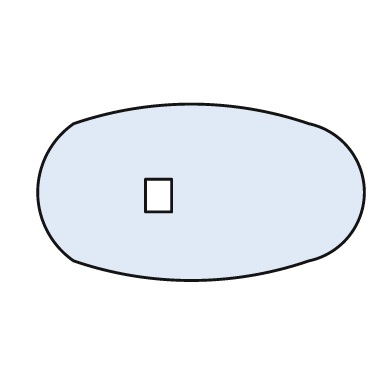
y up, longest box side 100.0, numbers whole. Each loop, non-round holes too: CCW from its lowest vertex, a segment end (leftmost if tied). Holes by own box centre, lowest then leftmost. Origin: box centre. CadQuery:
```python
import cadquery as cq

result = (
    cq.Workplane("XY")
    .moveTo(-39.0, -21.0)
    .threePointArc((-3.0, -27.0), (33.0, -21.0))
    .threePointArc((50.0, 0.0), (33.0, 21.0))
    .threePointArc((-3.0, 27.0), (-39.0, 21.0))
    .threePointArc((-50.0, 0.0), (-39.0, -21.0))
    .close()
    .moveTo(-17.0, -6.0)
    .lineTo(-9.0, -6.0)
    .lineTo(-9.0, 4.0)
    .lineTo(-17.0, 4.0)
    .close()
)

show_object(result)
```